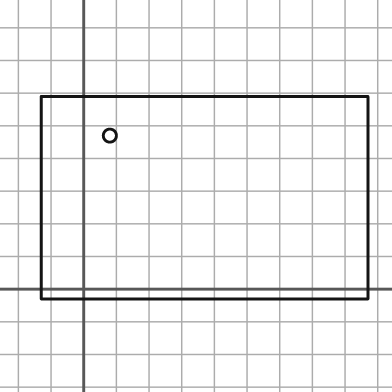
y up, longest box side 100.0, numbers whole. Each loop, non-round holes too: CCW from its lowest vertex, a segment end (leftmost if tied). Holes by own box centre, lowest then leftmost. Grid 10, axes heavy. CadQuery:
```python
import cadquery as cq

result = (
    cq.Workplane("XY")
    .moveTo(-13.0, -3.0)
    .lineTo(87.0, -3.0)
    .lineTo(87.0, 59.0)
    .lineTo(-13.0, 59.0)
    .close()
    .moveTo(8.0, 47.0)
    .circle(2.0)
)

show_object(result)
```